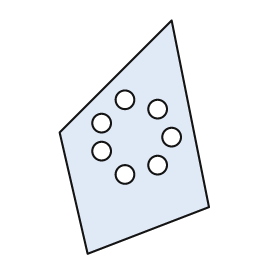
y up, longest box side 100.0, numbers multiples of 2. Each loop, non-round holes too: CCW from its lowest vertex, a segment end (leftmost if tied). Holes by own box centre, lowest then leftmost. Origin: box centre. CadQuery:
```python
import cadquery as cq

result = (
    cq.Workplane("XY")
    .moveTo(-20.0, -50.0)
    .lineTo(32.0, -30.0)
    .lineTo(16.0, 50.0)
    .lineTo(-32.0, 2.0)
    .close()
    .moveTo(-4.0, -16.0)
    .circle(4.0)
    .moveTo(10.0, -12.0)
    .circle(4.0)
    .moveTo(-14.0, -6.0)
    .circle(4.0)
    .moveTo(16.0, 0.0)
    .circle(4.0)
    .moveTo(-14.0, 6.0)
    .circle(4.0)
    .moveTo(10.0, 12.0)
    .circle(4.0)
    .moveTo(-4.0, 16.0)
    .circle(4.0)
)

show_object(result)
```